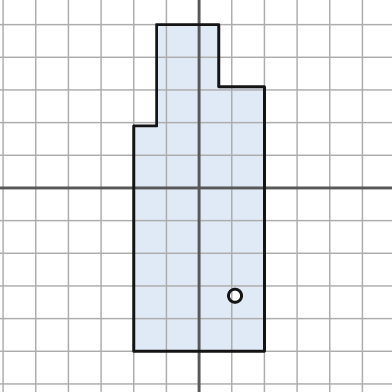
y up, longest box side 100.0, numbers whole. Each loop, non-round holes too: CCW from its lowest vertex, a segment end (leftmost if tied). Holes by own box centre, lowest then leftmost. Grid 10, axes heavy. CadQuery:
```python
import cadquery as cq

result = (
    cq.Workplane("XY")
    .moveTo(-20.0, -50.0)
    .lineTo(20.0, -50.0)
    .lineTo(20.0, 31.0)
    .lineTo(6.0, 31.0)
    .lineTo(6.0, 50.0)
    .lineTo(-13.0, 50.0)
    .lineTo(-13.0, 19.0)
    .lineTo(-20.0, 19.0)
    .close()
    .moveTo(11.0, -33.0)
    .circle(2.0)
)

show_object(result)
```